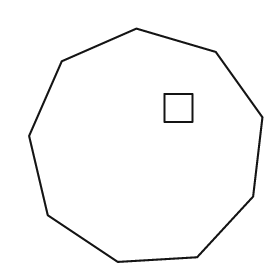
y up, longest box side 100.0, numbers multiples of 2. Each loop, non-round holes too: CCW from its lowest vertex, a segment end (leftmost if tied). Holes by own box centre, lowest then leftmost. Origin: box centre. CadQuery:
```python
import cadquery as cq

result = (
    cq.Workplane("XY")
    .moveTo(-12.0, -50.0)
    .lineTo(22.0, -48.0)
    .lineTo(46.0, -22.0)
    .lineTo(50.0, 12.0)
    .lineTo(30.0, 40.0)
    .lineTo(-4.0, 50.0)
    .lineTo(-36.0, 36.0)
    .lineTo(-50.0, 4.0)
    .lineTo(-42.0, -30.0)
    .close()
    .moveTo(8.0, 10.0)
    .lineTo(20.0, 10.0)
    .lineTo(20.0, 22.0)
    .lineTo(8.0, 22.0)
    .close()
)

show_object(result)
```